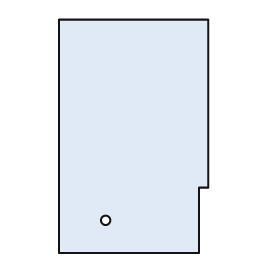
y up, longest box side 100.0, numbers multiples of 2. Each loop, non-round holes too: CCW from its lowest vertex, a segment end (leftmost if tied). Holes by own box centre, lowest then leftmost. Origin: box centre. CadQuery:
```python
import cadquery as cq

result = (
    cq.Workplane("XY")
    .moveTo(-32.0, -50.0)
    .lineTo(28.0, -50.0)
    .lineTo(28.0, -22.0)
    .lineTo(32.0, -22.0)
    .lineTo(32.0, 50.0)
    .lineTo(-32.0, 50.0)
    .close()
    .moveTo(-12.0, -36.0)
    .circle(2.0)
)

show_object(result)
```